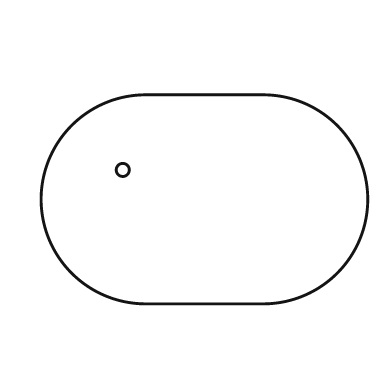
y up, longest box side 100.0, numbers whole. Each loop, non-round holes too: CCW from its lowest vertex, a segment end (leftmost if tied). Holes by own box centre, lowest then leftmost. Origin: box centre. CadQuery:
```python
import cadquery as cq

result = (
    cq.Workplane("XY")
    .moveTo(-18.0, -32.0)
    .lineTo(18.0, -32.0)
    .threePointArc((50.0, 0.0), (18.0, 32.0))
    .lineTo(-18.0, 32.0)
    .threePointArc((-50.0, 0.0), (-18.0, -32.0))
    .close()
    .moveTo(-25.0, 9.0)
    .circle(2.0)
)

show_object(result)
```